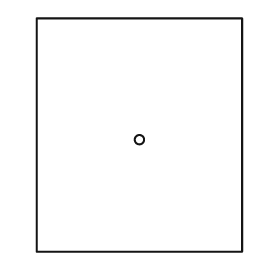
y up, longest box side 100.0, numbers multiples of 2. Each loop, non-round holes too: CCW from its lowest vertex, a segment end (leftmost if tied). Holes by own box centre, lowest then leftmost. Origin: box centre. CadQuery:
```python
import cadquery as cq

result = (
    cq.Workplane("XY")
    .moveTo(-44.0, -50.0)
    .lineTo(44.0, -50.0)
    .lineTo(44.0, 50.0)
    .lineTo(-44.0, 50.0)
    .close()
    .moveTo(0.0, -2.0)
    .circle(2.0)
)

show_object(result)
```